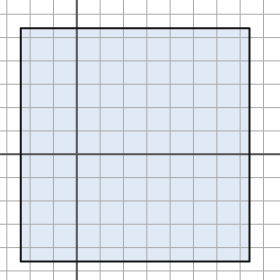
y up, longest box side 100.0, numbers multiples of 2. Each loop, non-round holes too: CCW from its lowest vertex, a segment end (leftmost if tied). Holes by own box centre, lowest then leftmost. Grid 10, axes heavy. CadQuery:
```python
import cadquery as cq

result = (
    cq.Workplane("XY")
    .moveTo(-24.0, -46.0)
    .lineTo(74.0, -46.0)
    .lineTo(74.0, 54.0)
    .lineTo(-24.0, 54.0)
    .close()
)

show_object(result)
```